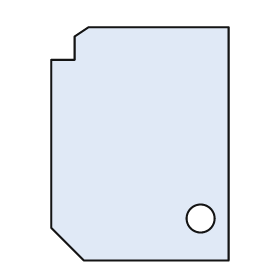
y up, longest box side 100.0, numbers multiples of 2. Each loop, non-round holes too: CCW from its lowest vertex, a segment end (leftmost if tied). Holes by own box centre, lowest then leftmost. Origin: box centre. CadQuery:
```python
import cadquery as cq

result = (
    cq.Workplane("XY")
    .moveTo(-24.0, -50.0)
    .lineTo(38.0, -50.0)
    .lineTo(38.0, 50.0)
    .lineTo(-22.0, 50.0)
    .lineTo(-28.0, 46.0)
    .lineTo(-28.0, 36.0)
    .lineTo(-38.0, 36.0)
    .lineTo(-38.0, -36.0)
    .close()
    .moveTo(26.0, -32.0)
    .circle(6.0)
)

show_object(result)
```